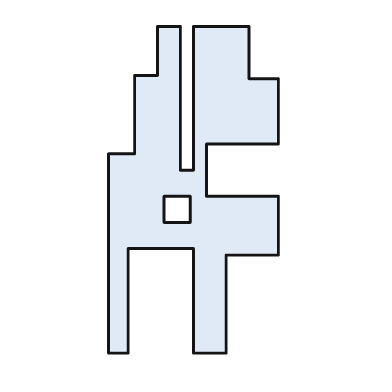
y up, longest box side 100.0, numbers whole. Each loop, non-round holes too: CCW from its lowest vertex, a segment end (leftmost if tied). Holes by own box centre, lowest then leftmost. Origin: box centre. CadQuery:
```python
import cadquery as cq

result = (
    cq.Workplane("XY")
    .moveTo(-26.0, -50.0)
    .lineTo(-20.0, -50.0)
    .lineTo(-20.0, -18.0)
    .lineTo(0.0, -18.0)
    .lineTo(0.0, -50.0)
    .lineTo(10.0, -50.0)
    .lineTo(10.0, -20.0)
    .lineTo(26.0, -20.0)
    .lineTo(26.0, -2.0)
    .lineTo(4.0, -2.0)
    .lineTo(4.0, 14.0)
    .lineTo(26.0, 14.0)
    .lineTo(26.0, 34.0)
    .lineTo(17.0, 34.0)
    .lineTo(17.0, 50.0)
    .lineTo(0.0, 50.0)
    .lineTo(0.0, 6.0)
    .lineTo(-4.0, 6.0)
    .lineTo(-4.0, 50.0)
    .lineTo(-11.0, 50.0)
    .lineTo(-11.0, 35.0)
    .lineTo(-18.0, 35.0)
    .lineTo(-18.0, 11.0)
    .lineTo(-26.0, 11.0)
    .close()
    .moveTo(-9.0, -10.0)
    .lineTo(-1.0, -10.0)
    .lineTo(-1.0, -2.0)
    .lineTo(-9.0, -2.0)
    .close()
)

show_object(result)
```